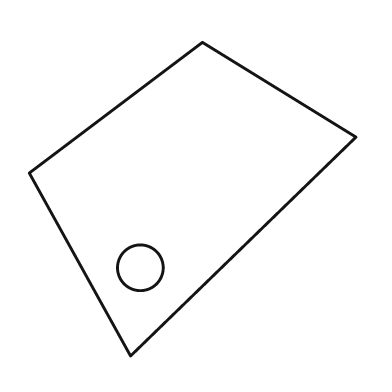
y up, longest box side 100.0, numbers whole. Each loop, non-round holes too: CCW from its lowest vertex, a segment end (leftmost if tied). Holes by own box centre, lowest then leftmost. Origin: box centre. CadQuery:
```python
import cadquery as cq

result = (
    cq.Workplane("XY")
    .moveTo(-19.0, -48.0)
    .lineTo(50.0, 19.0)
    .lineTo(3.0, 48.0)
    .lineTo(-50.0, 8.0)
    .close()
    .moveTo(-16.0, -21.0)
    .circle(7.0)
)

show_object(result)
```